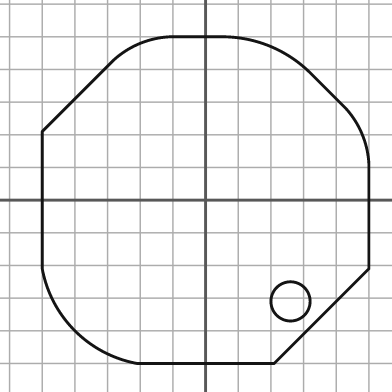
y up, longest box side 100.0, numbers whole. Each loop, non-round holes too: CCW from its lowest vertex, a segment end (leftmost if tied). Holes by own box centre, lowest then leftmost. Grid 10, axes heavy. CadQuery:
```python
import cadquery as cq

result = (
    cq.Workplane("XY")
    .moveTo(-21.0, -50.0)
    .lineTo(21.0, -50.0)
    .lineTo(50.0, -21.0)
    .lineTo(50.0, 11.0)
    .threePointArc((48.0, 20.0), (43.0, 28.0))
    .lineTo(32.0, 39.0)
    .threePointArc((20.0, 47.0), (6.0, 50.0))
    .lineTo(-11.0, 50.0)
    .threePointArc((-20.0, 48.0), (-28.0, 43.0))
    .lineTo(-50.0, 21.0)
    .lineTo(-50.0, -21.0)
    .threePointArc((-40.0, -40.0), (-21.0, -50.0))
    .close()
    .moveTo(26.0, -31.0)
    .circle(6.0)
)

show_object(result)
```